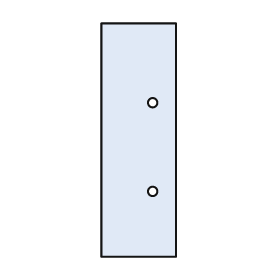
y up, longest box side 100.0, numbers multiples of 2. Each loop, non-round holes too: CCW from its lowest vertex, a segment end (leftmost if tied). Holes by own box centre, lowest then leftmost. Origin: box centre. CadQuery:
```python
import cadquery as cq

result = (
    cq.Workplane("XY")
    .moveTo(-16.0, -50.0)
    .lineTo(16.0, -50.0)
    .lineTo(16.0, 50.0)
    .lineTo(-16.0, 50.0)
    .close()
    .moveTo(6.0, -22.0)
    .circle(2.0)
    .moveTo(6.0, 16.0)
    .circle(2.0)
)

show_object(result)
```